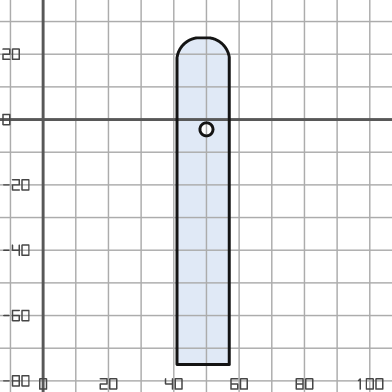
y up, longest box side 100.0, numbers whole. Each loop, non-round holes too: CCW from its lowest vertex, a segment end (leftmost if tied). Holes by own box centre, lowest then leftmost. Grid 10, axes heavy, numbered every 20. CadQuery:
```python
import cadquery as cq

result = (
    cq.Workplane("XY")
    .moveTo(41.0, -75.0)
    .lineTo(57.0, -75.0)
    .lineTo(57.0, 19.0)
    .threePointArc((55.0, 23.0), (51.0, 25.0))
    .lineTo(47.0, 25.0)
    .threePointArc((43.0, 23.0), (41.0, 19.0))
    .close()
    .moveTo(50.0, -3.0)
    .circle(2.0)
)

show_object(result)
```